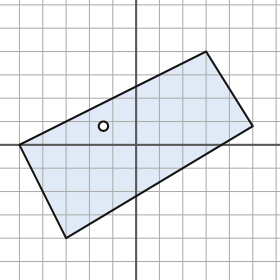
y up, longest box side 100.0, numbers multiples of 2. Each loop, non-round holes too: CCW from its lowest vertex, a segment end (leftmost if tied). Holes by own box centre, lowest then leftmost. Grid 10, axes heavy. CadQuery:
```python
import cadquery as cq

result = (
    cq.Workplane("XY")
    .moveTo(-30.0, -40.0)
    .lineTo(50.0, 8.0)
    .lineTo(30.0, 40.0)
    .lineTo(-50.0, 0.0)
    .close()
    .moveTo(-14.0, 8.0)
    .circle(2.0)
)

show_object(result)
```